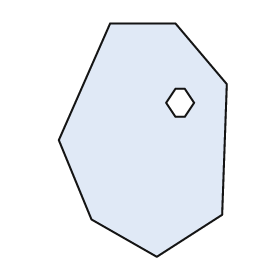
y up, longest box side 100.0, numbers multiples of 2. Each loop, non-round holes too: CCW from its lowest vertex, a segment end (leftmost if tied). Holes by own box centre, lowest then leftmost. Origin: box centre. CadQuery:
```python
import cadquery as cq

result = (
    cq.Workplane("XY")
    .moveTo(6.0, -50.0)
    .lineTo(34.0, -32.0)
    .lineTo(36.0, 24.0)
    .lineTo(14.0, 50.0)
    .lineTo(-14.0, 50.0)
    .lineTo(-36.0, 0.0)
    .lineTo(-22.0, -34.0)
    .close()
    .moveTo(14.0, 10.0)
    .lineTo(18.0, 10.0)
    .lineTo(22.0, 16.0)
    .lineTo(18.0, 22.0)
    .lineTo(14.0, 22.0)
    .lineTo(10.0, 16.0)
    .close()
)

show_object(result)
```